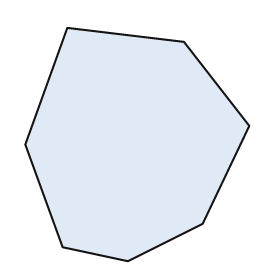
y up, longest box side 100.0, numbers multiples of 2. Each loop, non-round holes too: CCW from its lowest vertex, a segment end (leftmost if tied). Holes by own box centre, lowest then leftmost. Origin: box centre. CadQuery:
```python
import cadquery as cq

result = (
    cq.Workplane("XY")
    .moveTo(-4.0, -50.0)
    .lineTo(28.0, -34.0)
    .lineTo(48.0, 8.0)
    .lineTo(20.0, 44.0)
    .lineTo(-30.0, 50.0)
    .lineTo(-48.0, 0.0)
    .lineTo(-32.0, -44.0)
    .close()
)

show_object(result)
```